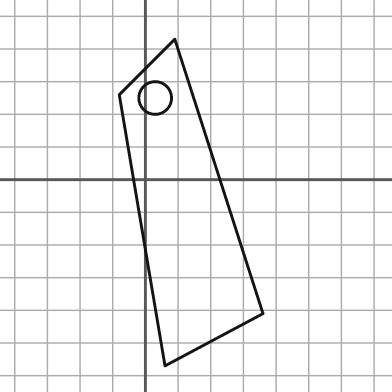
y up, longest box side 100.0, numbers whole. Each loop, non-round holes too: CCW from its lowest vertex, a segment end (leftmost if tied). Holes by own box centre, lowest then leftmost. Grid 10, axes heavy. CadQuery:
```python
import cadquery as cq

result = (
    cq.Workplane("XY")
    .moveTo(6.0, -57.0)
    .lineTo(36.0, -41.0)
    .lineTo(9.0, 43.0)
    .lineTo(-8.0, 26.0)
    .close()
    .moveTo(3.0, 25.0)
    .circle(5.0)
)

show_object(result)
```